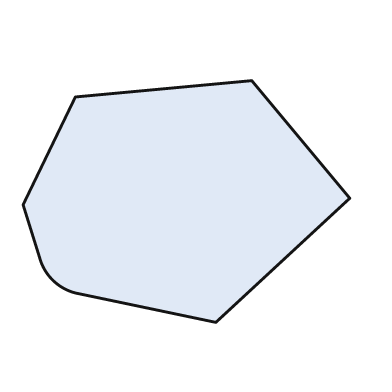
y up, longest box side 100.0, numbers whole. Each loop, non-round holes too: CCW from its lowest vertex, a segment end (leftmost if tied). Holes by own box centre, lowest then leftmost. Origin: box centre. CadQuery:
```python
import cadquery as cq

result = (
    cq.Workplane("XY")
    .moveTo(9.0, -37.0)
    .lineTo(50.0, 1.0)
    .lineTo(20.0, 37.0)
    .lineTo(-34.0, 32.0)
    .lineTo(-50.0, -1.0)
    .lineTo(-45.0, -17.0)
    .threePointArc((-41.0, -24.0), (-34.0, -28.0))
    .close()
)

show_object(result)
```